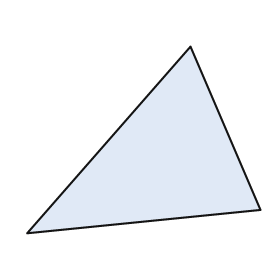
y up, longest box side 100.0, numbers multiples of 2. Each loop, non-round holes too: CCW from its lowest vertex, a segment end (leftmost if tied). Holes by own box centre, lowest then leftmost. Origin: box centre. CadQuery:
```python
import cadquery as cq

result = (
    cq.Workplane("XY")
    .moveTo(-50.0, -40.0)
    .lineTo(50.0, -30.0)
    .lineTo(20.0, 40.0)
    .close()
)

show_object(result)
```